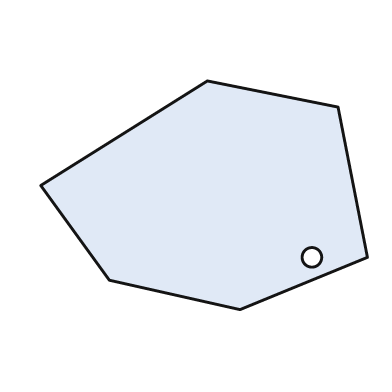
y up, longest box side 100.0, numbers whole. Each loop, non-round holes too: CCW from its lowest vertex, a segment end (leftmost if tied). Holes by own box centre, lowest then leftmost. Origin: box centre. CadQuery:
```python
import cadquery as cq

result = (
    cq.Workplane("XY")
    .moveTo(11.0, -35.0)
    .lineTo(50.0, -19.0)
    .lineTo(41.0, 27.0)
    .lineTo(1.0, 35.0)
    .lineTo(-50.0, 3.0)
    .lineTo(-29.0, -26.0)
    .close()
    .moveTo(33.0, -19.0)
    .circle(3.0)
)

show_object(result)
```